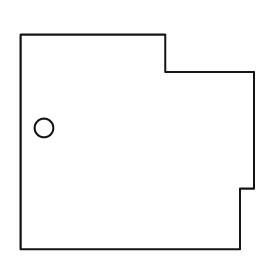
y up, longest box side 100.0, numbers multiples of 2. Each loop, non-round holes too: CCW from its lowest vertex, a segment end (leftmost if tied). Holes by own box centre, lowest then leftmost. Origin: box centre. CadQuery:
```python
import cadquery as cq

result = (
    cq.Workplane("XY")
    .moveTo(-50.0, -46.0)
    .lineTo(44.0, -46.0)
    .lineTo(44.0, -20.0)
    .lineTo(50.0, -20.0)
    .lineTo(50.0, 30.0)
    .lineTo(12.0, 30.0)
    .lineTo(12.0, 46.0)
    .lineTo(-50.0, 46.0)
    .close()
    .moveTo(-40.0, 6.0)
    .circle(4.0)
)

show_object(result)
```